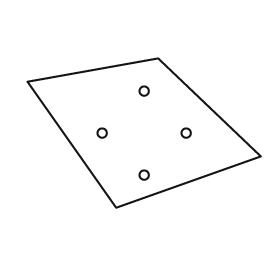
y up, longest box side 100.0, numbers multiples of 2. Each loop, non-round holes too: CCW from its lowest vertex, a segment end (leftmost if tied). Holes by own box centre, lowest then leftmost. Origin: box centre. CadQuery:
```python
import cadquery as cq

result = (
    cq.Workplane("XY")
    .moveTo(-12.0, -32.0)
    .lineTo(50.0, -10.0)
    .lineTo(6.0, 32.0)
    .lineTo(-50.0, 22.0)
    .close()
    .moveTo(0.0, -18.0)
    .circle(2.0)
    .moveTo(-18.0, 0.0)
    .circle(2.0)
    .moveTo(18.0, 0.0)
    .circle(2.0)
    .moveTo(0.0, 18.0)
    .circle(2.0)
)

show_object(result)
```